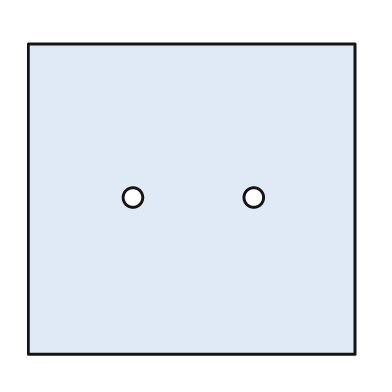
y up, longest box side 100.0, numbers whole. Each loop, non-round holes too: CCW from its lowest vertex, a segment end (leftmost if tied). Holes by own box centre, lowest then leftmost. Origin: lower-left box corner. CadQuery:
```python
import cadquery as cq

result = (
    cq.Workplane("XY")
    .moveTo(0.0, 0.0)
    .lineTo(100.0, 0.0)
    .lineTo(100.0, 95.0)
    .lineTo(0.0, 95.0)
    .close()
    .moveTo(32.0, 48.0)
    .circle(3.0)
    .moveTo(69.0, 48.0)
    .circle(3.0)
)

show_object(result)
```